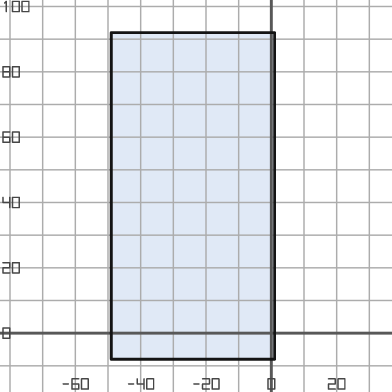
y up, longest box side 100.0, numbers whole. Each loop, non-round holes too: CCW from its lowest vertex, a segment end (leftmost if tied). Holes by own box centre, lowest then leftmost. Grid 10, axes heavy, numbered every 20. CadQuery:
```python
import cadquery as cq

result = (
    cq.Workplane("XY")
    .moveTo(-49.0, -8.0)
    .lineTo(1.0, -8.0)
    .lineTo(1.0, 92.0)
    .lineTo(-49.0, 92.0)
    .close()
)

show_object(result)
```